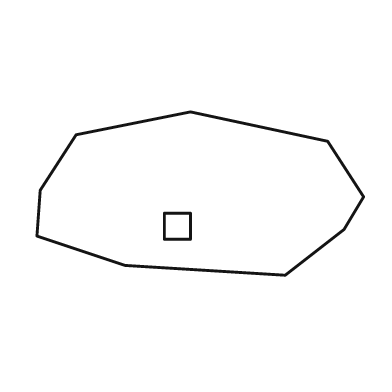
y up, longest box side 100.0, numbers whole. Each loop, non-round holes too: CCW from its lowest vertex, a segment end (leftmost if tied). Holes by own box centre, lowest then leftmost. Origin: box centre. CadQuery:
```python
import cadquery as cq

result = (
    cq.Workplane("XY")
    .moveTo(26.0, -25.0)
    .lineTo(44.0, -11.0)
    .lineTo(50.0, -1.0)
    .lineTo(39.0, 16.0)
    .lineTo(-3.0, 25.0)
    .lineTo(-38.0, 18.0)
    .lineTo(-49.0, 1.0)
    .lineTo(-50.0, -13.0)
    .lineTo(-23.0, -22.0)
    .close()
    .moveTo(-11.0, -14.0)
    .lineTo(-3.0, -14.0)
    .lineTo(-3.0, -6.0)
    .lineTo(-11.0, -6.0)
    .close()
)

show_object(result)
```